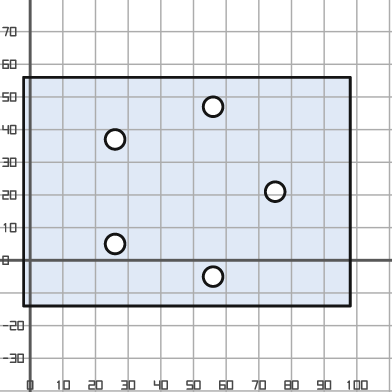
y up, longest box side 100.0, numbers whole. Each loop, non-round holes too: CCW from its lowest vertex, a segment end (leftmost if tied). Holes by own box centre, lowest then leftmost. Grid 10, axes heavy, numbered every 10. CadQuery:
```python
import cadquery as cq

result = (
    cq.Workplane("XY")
    .moveTo(-2.0, -14.0)
    .lineTo(98.0, -14.0)
    .lineTo(98.0, 56.0)
    .lineTo(-2.0, 56.0)
    .close()
    .moveTo(56.0, -5.0)
    .circle(3.0)
    .moveTo(26.0, 5.0)
    .circle(3.0)
    .moveTo(75.0, 21.0)
    .circle(3.0)
    .moveTo(26.0, 37.0)
    .circle(3.0)
    .moveTo(56.0, 47.0)
    .circle(3.0)
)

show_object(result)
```